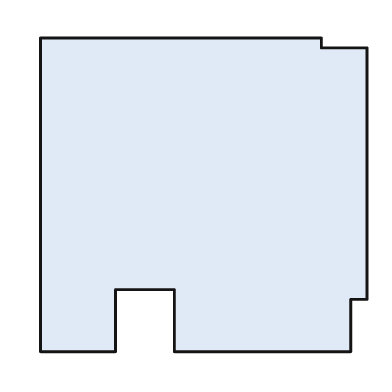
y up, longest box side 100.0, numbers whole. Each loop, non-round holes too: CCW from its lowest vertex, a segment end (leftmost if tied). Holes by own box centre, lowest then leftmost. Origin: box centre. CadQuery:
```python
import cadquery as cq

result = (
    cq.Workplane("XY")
    .moveTo(-50.0, -48.0)
    .lineTo(-27.0, -48.0)
    .lineTo(-27.0, -29.0)
    .lineTo(-9.0, -29.0)
    .lineTo(-9.0, -48.0)
    .lineTo(45.0, -48.0)
    .lineTo(45.0, -32.0)
    .lineTo(50.0, -32.0)
    .lineTo(50.0, 45.0)
    .lineTo(36.0, 45.0)
    .lineTo(36.0, 48.0)
    .lineTo(-50.0, 48.0)
    .close()
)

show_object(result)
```